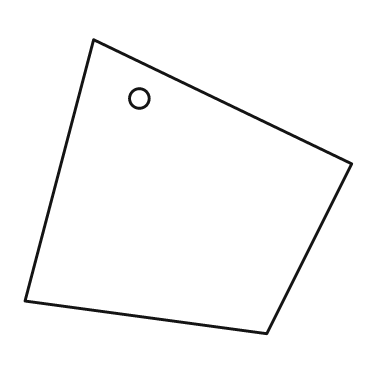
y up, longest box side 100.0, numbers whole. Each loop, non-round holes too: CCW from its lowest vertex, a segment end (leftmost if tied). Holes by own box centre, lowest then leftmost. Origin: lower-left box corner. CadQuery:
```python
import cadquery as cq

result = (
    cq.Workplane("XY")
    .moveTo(74.0, 0.0)
    .lineTo(100.0, 52.0)
    .lineTo(21.0, 90.0)
    .lineTo(0.0, 10.0)
    .close()
    .moveTo(35.0, 72.0)
    .circle(3.0)
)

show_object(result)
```